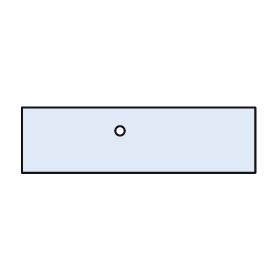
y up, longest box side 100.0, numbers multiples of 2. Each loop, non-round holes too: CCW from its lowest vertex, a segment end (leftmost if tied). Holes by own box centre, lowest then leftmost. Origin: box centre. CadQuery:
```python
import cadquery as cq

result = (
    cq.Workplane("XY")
    .moveTo(-50.0, -14.0)
    .lineTo(50.0, -14.0)
    .lineTo(50.0, 14.0)
    .lineTo(-50.0, 14.0)
    .close()
    .moveTo(-8.0, 4.0)
    .circle(2.0)
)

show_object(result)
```